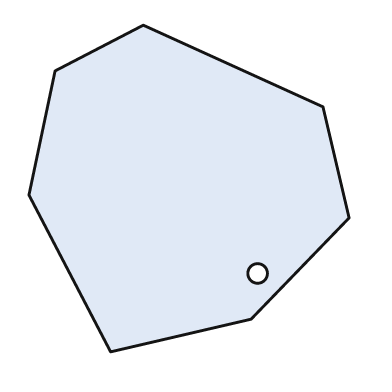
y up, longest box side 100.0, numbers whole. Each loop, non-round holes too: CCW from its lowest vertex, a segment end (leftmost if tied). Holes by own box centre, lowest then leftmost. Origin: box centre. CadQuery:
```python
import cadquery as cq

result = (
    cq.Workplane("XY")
    .moveTo(-24.0, -50.0)
    .lineTo(19.0, -40.0)
    .lineTo(49.0, -9.0)
    .lineTo(41.0, 25.0)
    .lineTo(-14.0, 50.0)
    .lineTo(-41.0, 36.0)
    .lineTo(-49.0, -2.0)
    .close()
    .moveTo(21.0, -26.0)
    .circle(3.0)
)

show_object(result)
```